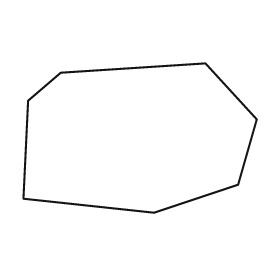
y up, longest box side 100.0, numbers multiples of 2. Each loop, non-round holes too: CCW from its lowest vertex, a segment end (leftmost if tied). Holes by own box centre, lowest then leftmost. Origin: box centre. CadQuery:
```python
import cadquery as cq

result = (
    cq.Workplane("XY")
    .moveTo(6.0, -32.0)
    .lineTo(42.0, -20.0)
    .lineTo(50.0, 8.0)
    .lineTo(28.0, 32.0)
    .lineTo(-34.0, 28.0)
    .lineTo(-48.0, 16.0)
    .lineTo(-50.0, -26.0)
    .close()
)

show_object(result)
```